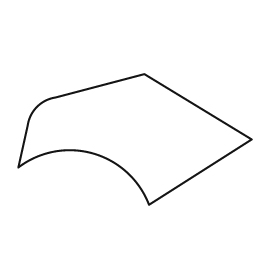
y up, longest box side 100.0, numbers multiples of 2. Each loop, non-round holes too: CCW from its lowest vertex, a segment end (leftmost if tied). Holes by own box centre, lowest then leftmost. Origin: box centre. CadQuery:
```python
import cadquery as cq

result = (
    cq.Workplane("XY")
    .moveTo(6.0, -28.0)
    .lineTo(50.0, 0.0)
    .lineTo(4.0, 28.0)
    .lineTo(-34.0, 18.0)
    .threePointArc((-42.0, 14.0), (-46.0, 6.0))
    .lineTo(-50.0, -12.0)
    .threePointArc((-18.0, -6.0), (6.0, -28.0))
    .close()
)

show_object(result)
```